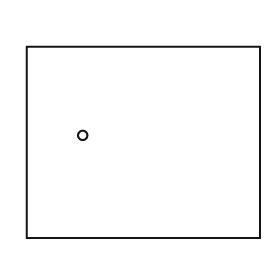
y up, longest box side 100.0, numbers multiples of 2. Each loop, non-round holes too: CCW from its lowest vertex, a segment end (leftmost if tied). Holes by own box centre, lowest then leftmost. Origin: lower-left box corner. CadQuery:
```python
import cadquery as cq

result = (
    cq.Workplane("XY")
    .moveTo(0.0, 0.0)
    .lineTo(100.0, 0.0)
    .lineTo(100.0, 82.0)
    .lineTo(0.0, 82.0)
    .close()
    .moveTo(24.0, 44.0)
    .circle(2.0)
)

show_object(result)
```